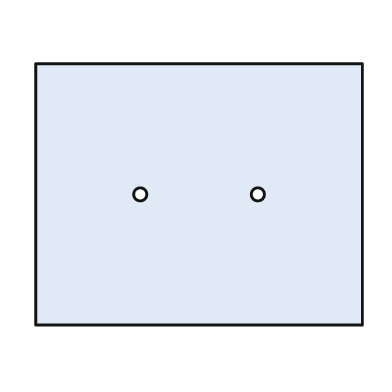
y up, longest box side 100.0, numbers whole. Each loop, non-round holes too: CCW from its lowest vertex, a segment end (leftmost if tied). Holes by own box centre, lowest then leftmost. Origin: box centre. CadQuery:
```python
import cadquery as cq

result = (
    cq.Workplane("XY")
    .moveTo(-50.0, -40.0)
    .lineTo(50.0, -40.0)
    .lineTo(50.0, 40.0)
    .lineTo(-50.0, 40.0)
    .close()
    .moveTo(-18.0, 0.0)
    .circle(2.0)
    .moveTo(18.0, 0.0)
    .circle(2.0)
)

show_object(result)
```